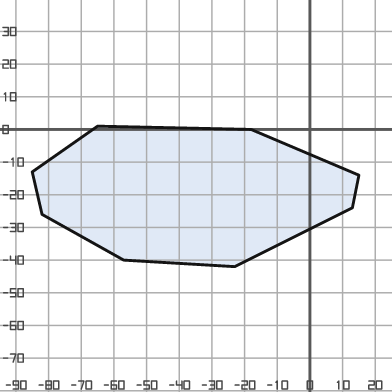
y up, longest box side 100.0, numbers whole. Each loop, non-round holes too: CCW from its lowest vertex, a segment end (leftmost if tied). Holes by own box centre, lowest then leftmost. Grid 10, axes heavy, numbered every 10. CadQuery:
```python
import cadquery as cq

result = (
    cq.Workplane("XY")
    .moveTo(-23.0, -42.0)
    .lineTo(13.0, -24.0)
    .lineTo(15.0, -14.0)
    .lineTo(-18.0, 0.0)
    .lineTo(-65.0, 1.0)
    .lineTo(-85.0, -13.0)
    .lineTo(-82.0, -26.0)
    .lineTo(-57.0, -40.0)
    .close()
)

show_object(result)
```